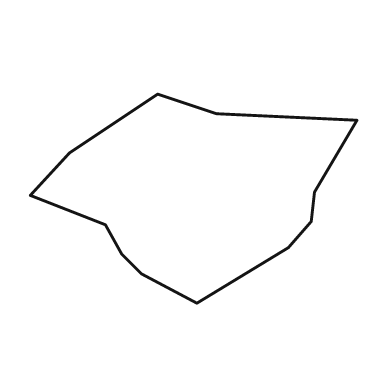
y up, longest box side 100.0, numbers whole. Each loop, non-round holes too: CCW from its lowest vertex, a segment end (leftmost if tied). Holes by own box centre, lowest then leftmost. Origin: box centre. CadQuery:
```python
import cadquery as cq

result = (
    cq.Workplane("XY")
    .moveTo(1.0, -32.0)
    .lineTo(29.0, -15.0)
    .lineTo(36.0, -7.0)
    .lineTo(37.0, 2.0)
    .lineTo(50.0, 24.0)
    .lineTo(7.0, 26.0)
    .lineTo(-11.0, 32.0)
    .lineTo(-38.0, 14.0)
    .lineTo(-50.0, 1.0)
    .lineTo(-27.0, -8.0)
    .lineTo(-22.0, -17.0)
    .lineTo(-16.0, -23.0)
    .close()
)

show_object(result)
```